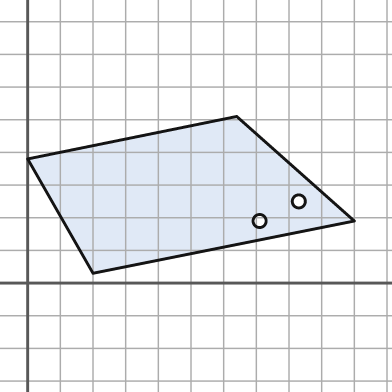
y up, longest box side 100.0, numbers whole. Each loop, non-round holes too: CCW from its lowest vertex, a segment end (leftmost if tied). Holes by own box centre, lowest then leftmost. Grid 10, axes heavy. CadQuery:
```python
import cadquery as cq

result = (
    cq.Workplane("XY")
    .moveTo(20.0, 3.0)
    .lineTo(100.0, 19.0)
    .lineTo(64.0, 51.0)
    .lineTo(0.0, 38.0)
    .close()
    .moveTo(71.0, 19.0)
    .circle(2.0)
    .moveTo(83.0, 25.0)
    .circle(2.0)
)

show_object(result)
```